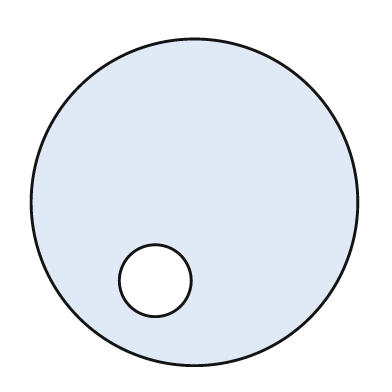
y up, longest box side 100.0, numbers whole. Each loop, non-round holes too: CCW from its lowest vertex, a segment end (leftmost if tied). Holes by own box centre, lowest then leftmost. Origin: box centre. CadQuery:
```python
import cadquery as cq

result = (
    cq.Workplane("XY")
    .moveTo(0.0, 0.0)
    .circle(50.0)
    .moveTo(-12.0, -24.0)
    .circle(11.0)
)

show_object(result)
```